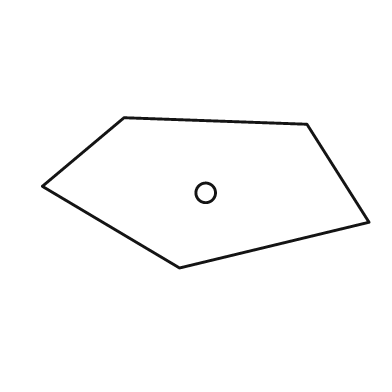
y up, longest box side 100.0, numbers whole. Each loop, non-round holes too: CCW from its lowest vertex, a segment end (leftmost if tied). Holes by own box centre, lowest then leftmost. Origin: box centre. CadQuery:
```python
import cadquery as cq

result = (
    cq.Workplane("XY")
    .moveTo(-8.0, -23.0)
    .lineTo(50.0, -9.0)
    .lineTo(31.0, 21.0)
    .lineTo(-25.0, 23.0)
    .lineTo(-50.0, 2.0)
    .close()
    .moveTo(0.0, 0.0)
    .circle(3.0)
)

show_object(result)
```